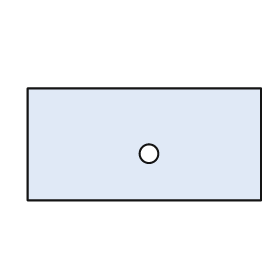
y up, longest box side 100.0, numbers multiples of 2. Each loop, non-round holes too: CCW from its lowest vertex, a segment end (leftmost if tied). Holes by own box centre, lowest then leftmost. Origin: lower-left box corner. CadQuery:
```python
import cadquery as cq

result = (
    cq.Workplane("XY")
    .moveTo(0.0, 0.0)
    .lineTo(100.0, 0.0)
    .lineTo(100.0, 48.0)
    .lineTo(0.0, 48.0)
    .close()
    .moveTo(52.0, 20.0)
    .circle(4.0)
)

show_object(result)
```